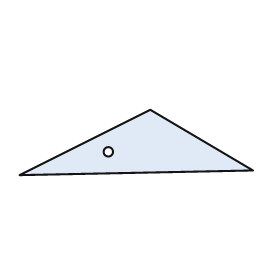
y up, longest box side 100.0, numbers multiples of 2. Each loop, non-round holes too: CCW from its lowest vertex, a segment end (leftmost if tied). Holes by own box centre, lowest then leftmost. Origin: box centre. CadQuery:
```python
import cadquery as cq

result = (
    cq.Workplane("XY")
    .moveTo(-50.0, -14.0)
    .lineTo(50.0, -12.0)
    .lineTo(6.0, 14.0)
    .close()
    .moveTo(-12.0, -4.0)
    .circle(2.0)
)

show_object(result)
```